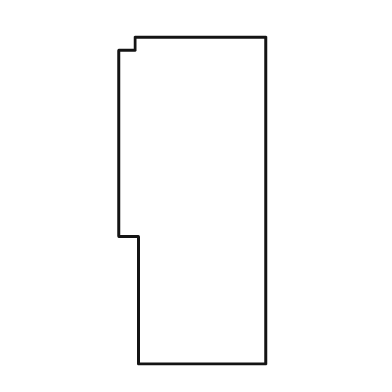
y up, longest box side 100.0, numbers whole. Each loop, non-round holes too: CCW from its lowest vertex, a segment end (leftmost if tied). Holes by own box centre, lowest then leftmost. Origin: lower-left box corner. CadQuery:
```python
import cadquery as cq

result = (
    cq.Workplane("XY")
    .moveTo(6.0, 0.0)
    .lineTo(45.0, 0.0)
    .lineTo(45.0, 100.0)
    .lineTo(5.0, 100.0)
    .lineTo(5.0, 96.0)
    .lineTo(0.0, 96.0)
    .lineTo(0.0, 39.0)
    .lineTo(6.0, 39.0)
    .close()
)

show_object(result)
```